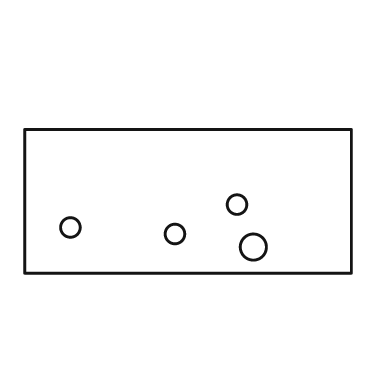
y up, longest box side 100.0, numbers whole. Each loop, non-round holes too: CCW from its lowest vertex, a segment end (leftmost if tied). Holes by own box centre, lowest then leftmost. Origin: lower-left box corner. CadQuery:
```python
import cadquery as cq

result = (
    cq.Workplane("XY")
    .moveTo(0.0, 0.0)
    .lineTo(100.0, 0.0)
    .lineTo(100.0, 44.0)
    .lineTo(0.0, 44.0)
    .close()
    .moveTo(70.0, 8.0)
    .circle(4.0)
    .moveTo(46.0, 12.0)
    .circle(3.0)
    .moveTo(14.0, 14.0)
    .circle(3.0)
    .moveTo(65.0, 21.0)
    .circle(3.0)
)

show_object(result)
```